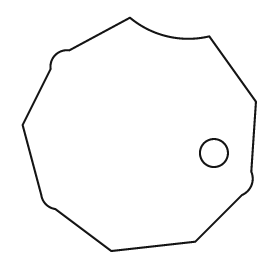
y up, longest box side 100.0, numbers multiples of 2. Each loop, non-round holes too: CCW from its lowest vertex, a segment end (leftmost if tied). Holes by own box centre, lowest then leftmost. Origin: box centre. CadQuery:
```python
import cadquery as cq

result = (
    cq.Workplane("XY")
    .moveTo(-12.0, -50.0)
    .lineTo(24.0, -46.0)
    .lineTo(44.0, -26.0)
    .threePointArc((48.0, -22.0), (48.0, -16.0))
    .lineTo(50.0, 14.0)
    .lineTo(30.0, 42.0)
    .threePointArc((12.0, 42.0), (-4.0, 50.0))
    .lineTo(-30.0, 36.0)
    .threePointArc((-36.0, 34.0), (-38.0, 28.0))
    .lineTo(-50.0, 4.0)
    .lineTo(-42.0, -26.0)
    .threePointArc((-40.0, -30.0), (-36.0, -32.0))
    .close()
    .moveTo(32.0, -8.0)
    .circle(6.0)
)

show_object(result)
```